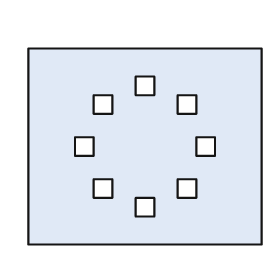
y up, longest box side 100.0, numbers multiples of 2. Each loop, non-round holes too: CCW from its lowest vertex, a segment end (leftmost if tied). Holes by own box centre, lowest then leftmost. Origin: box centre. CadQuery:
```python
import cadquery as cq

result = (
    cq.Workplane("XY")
    .moveTo(-50.0, -42.0)
    .lineTo(50.0, -42.0)
    .lineTo(50.0, 42.0)
    .lineTo(-50.0, 42.0)
    .close()
    .moveTo(-4.0, -30.0)
    .lineTo(4.0, -30.0)
    .lineTo(4.0, -22.0)
    .lineTo(-4.0, -22.0)
    .close()
    .moveTo(-22.0, -22.0)
    .lineTo(-14.0, -22.0)
    .lineTo(-14.0, -14.0)
    .lineTo(-22.0, -14.0)
    .close()
    .moveTo(14.0, -22.0)
    .lineTo(22.0, -22.0)
    .lineTo(22.0, -14.0)
    .lineTo(14.0, -14.0)
    .close()
    .moveTo(-30.0, -4.0)
    .lineTo(-22.0, -4.0)
    .lineTo(-22.0, 4.0)
    .lineTo(-30.0, 4.0)
    .close()
    .moveTo(22.0, -4.0)
    .lineTo(30.0, -4.0)
    .lineTo(30.0, 4.0)
    .lineTo(22.0, 4.0)
    .close()
    .moveTo(-22.0, 14.0)
    .lineTo(-14.0, 14.0)
    .lineTo(-14.0, 22.0)
    .lineTo(-22.0, 22.0)
    .close()
    .moveTo(14.0, 14.0)
    .lineTo(22.0, 14.0)
    .lineTo(22.0, 22.0)
    .lineTo(14.0, 22.0)
    .close()
    .moveTo(-4.0, 22.0)
    .lineTo(4.0, 22.0)
    .lineTo(4.0, 30.0)
    .lineTo(-4.0, 30.0)
    .close()
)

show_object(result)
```